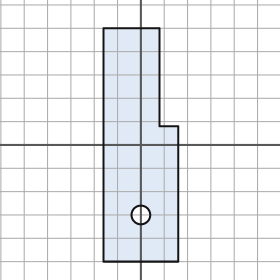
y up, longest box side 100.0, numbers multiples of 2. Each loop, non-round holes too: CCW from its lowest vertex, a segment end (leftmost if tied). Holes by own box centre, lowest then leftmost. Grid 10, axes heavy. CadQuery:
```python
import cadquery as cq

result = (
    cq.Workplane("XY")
    .moveTo(-16.0, -50.0)
    .lineTo(16.0, -50.0)
    .lineTo(16.0, 8.0)
    .lineTo(8.0, 8.0)
    .lineTo(8.0, 50.0)
    .lineTo(-16.0, 50.0)
    .close()
    .moveTo(0.0, -30.0)
    .circle(4.0)
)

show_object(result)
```